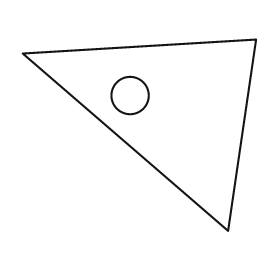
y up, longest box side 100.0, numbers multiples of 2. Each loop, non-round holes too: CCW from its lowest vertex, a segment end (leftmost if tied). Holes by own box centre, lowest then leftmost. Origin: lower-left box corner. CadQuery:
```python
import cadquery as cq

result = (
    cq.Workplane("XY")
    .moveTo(88.0, 0.0)
    .lineTo(100.0, 82.0)
    .lineTo(0.0, 76.0)
    .close()
    .moveTo(46.0, 58.0)
    .circle(8.0)
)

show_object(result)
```